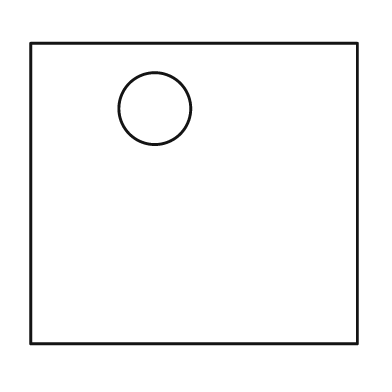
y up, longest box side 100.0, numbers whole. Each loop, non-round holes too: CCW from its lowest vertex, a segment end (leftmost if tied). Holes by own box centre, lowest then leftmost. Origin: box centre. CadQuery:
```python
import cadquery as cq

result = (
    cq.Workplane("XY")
    .moveTo(-50.0, -46.0)
    .lineTo(50.0, -46.0)
    .lineTo(50.0, 46.0)
    .lineTo(-50.0, 46.0)
    .close()
    .moveTo(-12.0, 26.0)
    .circle(11.0)
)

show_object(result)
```